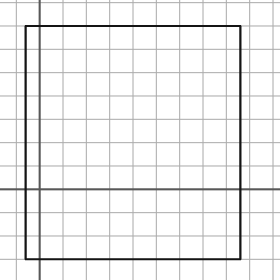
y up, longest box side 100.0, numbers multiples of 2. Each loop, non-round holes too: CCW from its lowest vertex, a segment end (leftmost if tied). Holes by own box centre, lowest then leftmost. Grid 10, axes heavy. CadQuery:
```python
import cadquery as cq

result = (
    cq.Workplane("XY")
    .moveTo(-6.0, -30.0)
    .lineTo(86.0, -30.0)
    .lineTo(86.0, 70.0)
    .lineTo(-6.0, 70.0)
    .close()
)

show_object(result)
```